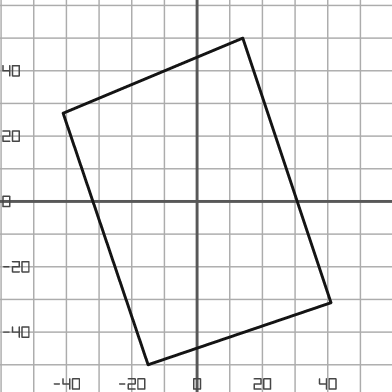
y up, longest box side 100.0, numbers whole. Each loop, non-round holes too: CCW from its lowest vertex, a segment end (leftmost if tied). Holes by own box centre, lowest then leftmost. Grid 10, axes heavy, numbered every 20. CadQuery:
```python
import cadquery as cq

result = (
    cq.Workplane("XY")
    .moveTo(-15.0, -50.0)
    .lineTo(41.0, -31.0)
    .lineTo(14.0, 50.0)
    .lineTo(-41.0, 27.0)
    .close()
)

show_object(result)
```